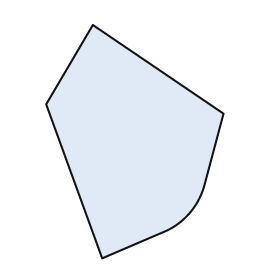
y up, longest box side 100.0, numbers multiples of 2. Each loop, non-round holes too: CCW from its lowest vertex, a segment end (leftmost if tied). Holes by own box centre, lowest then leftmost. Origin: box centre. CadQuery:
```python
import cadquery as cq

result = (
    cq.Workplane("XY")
    .moveTo(-14.0, -50.0)
    .lineTo(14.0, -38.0)
    .threePointArc((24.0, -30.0), (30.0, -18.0))
    .lineTo(38.0, 12.0)
    .lineTo(-18.0, 50.0)
    .lineTo(-38.0, 16.0)
    .close()
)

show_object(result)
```